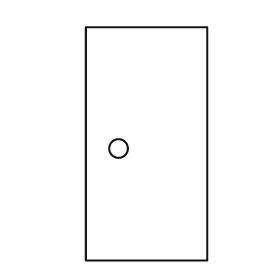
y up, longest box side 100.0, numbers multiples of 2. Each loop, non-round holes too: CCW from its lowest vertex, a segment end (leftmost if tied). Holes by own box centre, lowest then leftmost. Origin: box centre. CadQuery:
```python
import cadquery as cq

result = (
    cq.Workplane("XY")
    .moveTo(-26.0, -50.0)
    .lineTo(26.0, -50.0)
    .lineTo(26.0, 50.0)
    .lineTo(-26.0, 50.0)
    .close()
    .moveTo(-12.0, -2.0)
    .circle(4.0)
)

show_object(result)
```